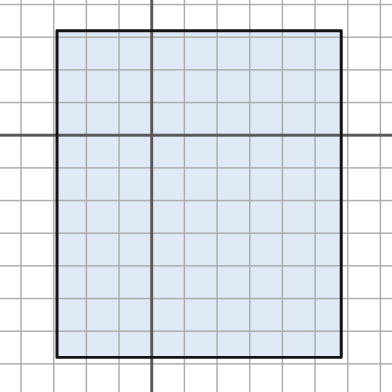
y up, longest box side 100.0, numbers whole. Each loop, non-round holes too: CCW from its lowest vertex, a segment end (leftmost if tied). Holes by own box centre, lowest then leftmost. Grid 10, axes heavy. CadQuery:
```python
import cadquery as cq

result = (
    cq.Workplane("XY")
    .moveTo(-29.0, -68.0)
    .lineTo(58.0, -68.0)
    .lineTo(58.0, 32.0)
    .lineTo(-29.0, 32.0)
    .close()
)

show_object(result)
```